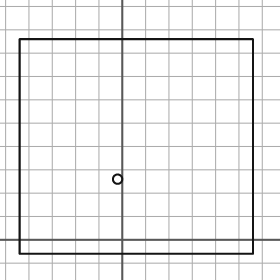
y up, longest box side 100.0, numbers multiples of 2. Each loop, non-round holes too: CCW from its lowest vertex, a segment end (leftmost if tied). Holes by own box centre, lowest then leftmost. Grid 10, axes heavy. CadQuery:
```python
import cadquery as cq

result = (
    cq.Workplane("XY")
    .moveTo(-44.0, -6.0)
    .lineTo(56.0, -6.0)
    .lineTo(56.0, 86.0)
    .lineTo(-44.0, 86.0)
    .close()
    .moveTo(-2.0, 26.0)
    .circle(2.0)
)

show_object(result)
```